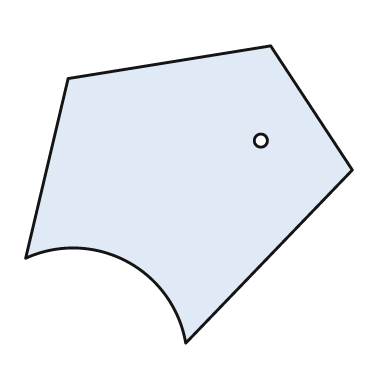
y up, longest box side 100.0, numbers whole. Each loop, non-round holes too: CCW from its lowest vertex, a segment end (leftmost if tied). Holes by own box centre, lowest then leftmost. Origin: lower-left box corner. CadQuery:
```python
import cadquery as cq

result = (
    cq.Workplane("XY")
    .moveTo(49.0, 0.0)
    .lineTo(100.0, 53.0)
    .lineTo(75.0, 91.0)
    .lineTo(13.0, 81.0)
    .lineTo(0.0, 26.0)
    .threePointArc((31.0, 25.0), (49.0, 0.0))
    .close()
    .moveTo(72.0, 62.0)
    .circle(2.0)
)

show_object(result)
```